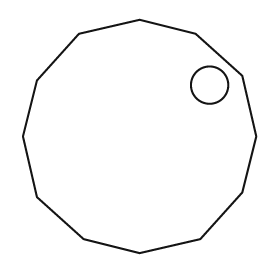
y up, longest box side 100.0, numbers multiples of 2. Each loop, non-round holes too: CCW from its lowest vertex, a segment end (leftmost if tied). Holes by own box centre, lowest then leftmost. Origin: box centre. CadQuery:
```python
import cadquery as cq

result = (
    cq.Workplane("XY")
    .moveTo(0.0, -50.0)
    .lineTo(26.0, -44.0)
    .lineTo(44.0, -24.0)
    .lineTo(50.0, 0.0)
    .lineTo(44.0, 26.0)
    .lineTo(24.0, 44.0)
    .lineTo(0.0, 50.0)
    .lineTo(-26.0, 44.0)
    .lineTo(-44.0, 24.0)
    .lineTo(-50.0, 0.0)
    .lineTo(-44.0, -26.0)
    .lineTo(-24.0, -44.0)
    .close()
    .moveTo(30.0, 22.0)
    .circle(8.0)
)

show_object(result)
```